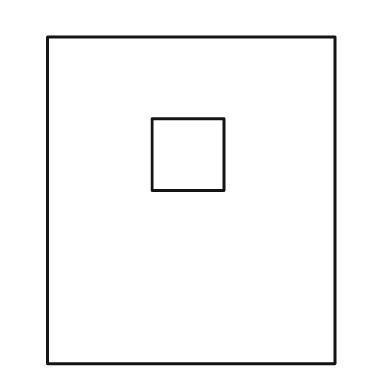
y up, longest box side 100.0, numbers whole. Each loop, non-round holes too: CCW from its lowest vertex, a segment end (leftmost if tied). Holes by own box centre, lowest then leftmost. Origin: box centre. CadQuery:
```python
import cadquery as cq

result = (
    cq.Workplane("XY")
    .moveTo(-44.0, -50.0)
    .lineTo(44.0, -50.0)
    .lineTo(44.0, 50.0)
    .lineTo(-44.0, 50.0)
    .close()
    .moveTo(-12.0, 3.0)
    .lineTo(10.0, 3.0)
    .lineTo(10.0, 25.0)
    .lineTo(-12.0, 25.0)
    .close()
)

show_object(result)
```